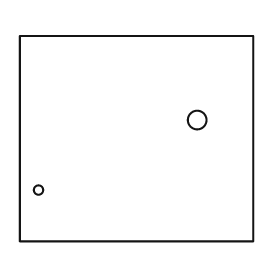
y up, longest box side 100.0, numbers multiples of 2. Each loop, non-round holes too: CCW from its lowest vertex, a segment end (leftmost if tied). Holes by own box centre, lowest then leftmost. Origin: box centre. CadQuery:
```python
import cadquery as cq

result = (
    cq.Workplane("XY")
    .moveTo(-50.0, -44.0)
    .lineTo(50.0, -44.0)
    .lineTo(50.0, 44.0)
    .lineTo(-50.0, 44.0)
    .close()
    .moveTo(-42.0, -22.0)
    .circle(2.0)
    .moveTo(26.0, 8.0)
    .circle(4.0)
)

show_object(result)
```